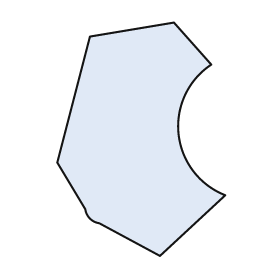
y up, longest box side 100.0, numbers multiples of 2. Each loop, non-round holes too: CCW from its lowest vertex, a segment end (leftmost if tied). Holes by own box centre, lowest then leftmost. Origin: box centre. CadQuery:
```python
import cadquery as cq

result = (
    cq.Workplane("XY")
    .moveTo(8.0, -50.0)
    .lineTo(36.0, -24.0)
    .threePointArc((16.0, 2.0), (30.0, 32.0))
    .lineTo(14.0, 50.0)
    .lineTo(-22.0, 44.0)
    .lineTo(-36.0, -10.0)
    .lineTo(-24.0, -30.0)
    .threePointArc((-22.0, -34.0), (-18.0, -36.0))
    .close()
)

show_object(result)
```